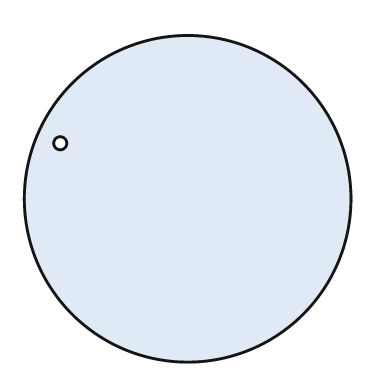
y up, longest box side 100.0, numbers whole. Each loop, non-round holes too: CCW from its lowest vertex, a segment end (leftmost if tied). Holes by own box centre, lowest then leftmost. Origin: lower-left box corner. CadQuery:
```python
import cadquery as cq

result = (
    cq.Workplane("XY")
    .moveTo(50.0, 50.0)
    .circle(50.0)
    .moveTo(11.0, 67.0)
    .circle(2.0)
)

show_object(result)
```